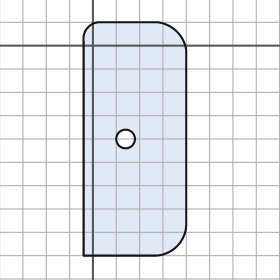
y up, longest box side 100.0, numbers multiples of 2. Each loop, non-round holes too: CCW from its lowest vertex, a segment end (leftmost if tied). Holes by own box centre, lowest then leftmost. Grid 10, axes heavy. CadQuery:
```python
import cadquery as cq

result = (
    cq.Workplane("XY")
    .moveTo(-4.0, -90.0)
    .lineTo(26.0, -90.0)
    .threePointArc((36.0, -86.0), (40.0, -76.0))
    .lineTo(40.0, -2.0)
    .threePointArc((36.0, 6.0), (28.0, 10.0))
    .lineTo(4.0, 10.0)
    .threePointArc((-2.0, 8.0), (-4.0, 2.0))
    .close()
    .moveTo(14.0, -40.0)
    .circle(4.0)
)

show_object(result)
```